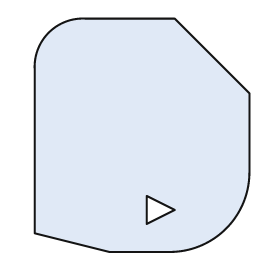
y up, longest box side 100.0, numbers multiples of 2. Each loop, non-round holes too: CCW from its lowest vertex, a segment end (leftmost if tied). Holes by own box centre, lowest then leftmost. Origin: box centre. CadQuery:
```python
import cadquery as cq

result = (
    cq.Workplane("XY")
    .moveTo(-14.0, -50.0)
    .lineTo(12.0, -50.0)
    .threePointArc((36.0, -40.0), (46.0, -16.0))
    .lineTo(46.0, 18.0)
    .lineTo(14.0, 50.0)
    .lineTo(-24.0, 50.0)
    .threePointArc((-40.0, 44.0), (-46.0, 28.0))
    .lineTo(-46.0, -42.0)
    .close()
    .moveTo(2.0, -38.0)
    .lineTo(14.0, -32.0)
    .lineTo(2.0, -26.0)
    .close()
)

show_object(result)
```